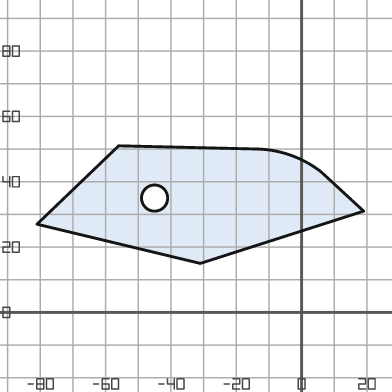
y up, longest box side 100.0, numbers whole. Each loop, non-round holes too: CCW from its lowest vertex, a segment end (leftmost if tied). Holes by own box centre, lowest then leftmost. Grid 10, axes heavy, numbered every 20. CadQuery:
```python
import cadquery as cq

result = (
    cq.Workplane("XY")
    .moveTo(-31.0, 15.0)
    .lineTo(19.0, 31.0)
    .lineTo(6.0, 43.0)
    .threePointArc((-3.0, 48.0), (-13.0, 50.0))
    .lineTo(-56.0, 51.0)
    .lineTo(-81.0, 27.0)
    .close()
    .moveTo(-45.0, 35.0)
    .circle(4.0)
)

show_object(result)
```